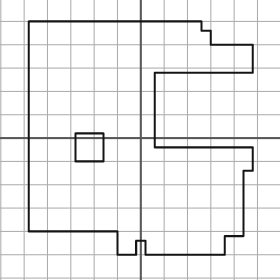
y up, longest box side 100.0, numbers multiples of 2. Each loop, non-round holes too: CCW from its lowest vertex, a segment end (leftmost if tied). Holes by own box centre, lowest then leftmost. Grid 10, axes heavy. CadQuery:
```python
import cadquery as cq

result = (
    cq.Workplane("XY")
    .moveTo(-10.0, -50.0)
    .lineTo(-2.0, -50.0)
    .lineTo(-2.0, -44.0)
    .lineTo(2.0, -44.0)
    .lineTo(2.0, -50.0)
    .lineTo(36.0, -50.0)
    .lineTo(36.0, -42.0)
    .lineTo(44.0, -42.0)
    .lineTo(44.0, -14.0)
    .lineTo(48.0, -14.0)
    .lineTo(48.0, -4.0)
    .lineTo(6.0, -4.0)
    .lineTo(6.0, 28.0)
    .lineTo(48.0, 28.0)
    .lineTo(48.0, 40.0)
    .lineTo(30.0, 40.0)
    .lineTo(30.0, 46.0)
    .lineTo(26.0, 46.0)
    .lineTo(26.0, 50.0)
    .lineTo(-48.0, 50.0)
    .lineTo(-48.0, -40.0)
    .lineTo(-10.0, -40.0)
    .close()
    .moveTo(-28.0, -10.0)
    .lineTo(-16.0, -10.0)
    .lineTo(-16.0, 2.0)
    .lineTo(-28.0, 2.0)
    .close()
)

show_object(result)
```